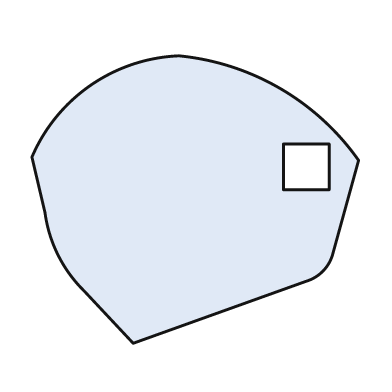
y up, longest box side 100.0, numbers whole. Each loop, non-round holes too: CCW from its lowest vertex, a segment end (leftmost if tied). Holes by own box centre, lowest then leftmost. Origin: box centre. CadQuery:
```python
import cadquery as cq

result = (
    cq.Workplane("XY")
    .moveTo(-19.0, -44.0)
    .lineTo(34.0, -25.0)
    .threePointArc((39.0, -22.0), (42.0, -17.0))
    .lineTo(50.0, 12.0)
    .threePointArc((26.0, 34.0), (-5.0, 44.0))
    .threePointArc((-32.0, 35.0), (-50.0, 13.0))
    .lineTo(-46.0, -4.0)
    .threePointArc((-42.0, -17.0), (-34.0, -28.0))
    .close()
    .moveTo(27.0, 3.0)
    .lineTo(41.0, 3.0)
    .lineTo(41.0, 17.0)
    .lineTo(27.0, 17.0)
    .close()
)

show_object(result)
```